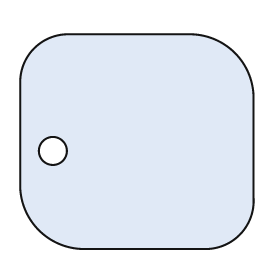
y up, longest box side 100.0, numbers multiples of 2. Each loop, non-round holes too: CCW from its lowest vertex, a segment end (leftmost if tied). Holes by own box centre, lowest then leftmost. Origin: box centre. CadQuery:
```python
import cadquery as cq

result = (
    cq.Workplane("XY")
    .moveTo(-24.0, -46.0)
    .lineTo(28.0, -46.0)
    .threePointArc((44.0, -40.0), (50.0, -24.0))
    .lineTo(50.0, 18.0)
    .threePointArc((42.0, 38.0), (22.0, 46.0))
    .lineTo(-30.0, 46.0)
    .threePointArc((-44.0, 40.0), (-50.0, 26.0))
    .lineTo(-50.0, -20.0)
    .threePointArc((-42.0, -38.0), (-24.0, -46.0))
    .close()
    .moveTo(-36.0, -4.0)
    .circle(6.0)
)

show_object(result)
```